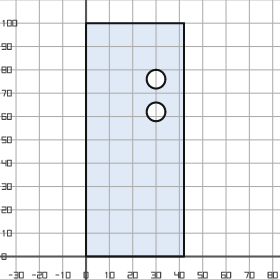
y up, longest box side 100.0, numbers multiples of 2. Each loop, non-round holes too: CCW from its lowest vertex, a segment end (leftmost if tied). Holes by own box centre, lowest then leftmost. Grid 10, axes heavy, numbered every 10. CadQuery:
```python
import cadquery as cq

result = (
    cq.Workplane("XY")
    .moveTo(0.0, 0.0)
    .lineTo(42.0, 0.0)
    .lineTo(42.0, 100.0)
    .lineTo(0.0, 100.0)
    .close()
    .moveTo(30.0, 62.0)
    .circle(4.0)
    .moveTo(30.0, 76.0)
    .circle(4.0)
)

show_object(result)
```